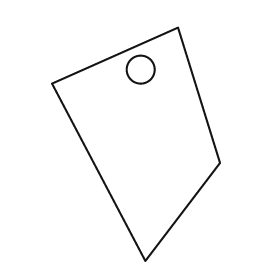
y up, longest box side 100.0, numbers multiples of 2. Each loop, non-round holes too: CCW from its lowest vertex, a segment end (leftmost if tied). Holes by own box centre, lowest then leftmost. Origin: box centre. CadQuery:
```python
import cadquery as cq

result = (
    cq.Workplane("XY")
    .moveTo(4.0, -50.0)
    .lineTo(36.0, -8.0)
    .lineTo(18.0, 50.0)
    .lineTo(-36.0, 26.0)
    .close()
    .moveTo(2.0, 32.0)
    .circle(6.0)
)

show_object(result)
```